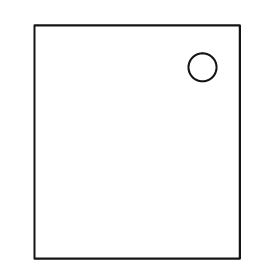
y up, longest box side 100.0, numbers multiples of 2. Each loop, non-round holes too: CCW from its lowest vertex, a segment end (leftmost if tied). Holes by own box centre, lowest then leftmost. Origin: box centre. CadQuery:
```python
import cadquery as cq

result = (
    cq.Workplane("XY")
    .moveTo(-44.0, -50.0)
    .lineTo(44.0, -50.0)
    .lineTo(44.0, 50.0)
    .lineTo(-44.0, 50.0)
    .close()
    .moveTo(28.0, 32.0)
    .circle(6.0)
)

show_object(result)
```